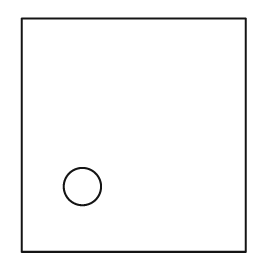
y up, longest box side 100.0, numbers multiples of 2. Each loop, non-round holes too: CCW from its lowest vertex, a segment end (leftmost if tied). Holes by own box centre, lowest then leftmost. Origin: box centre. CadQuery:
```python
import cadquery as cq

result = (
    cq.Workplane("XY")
    .moveTo(-48.0, -50.0)
    .lineTo(48.0, -50.0)
    .lineTo(48.0, 50.0)
    .lineTo(-48.0, 50.0)
    .close()
    .moveTo(-22.0, -22.0)
    .circle(8.0)
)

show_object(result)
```